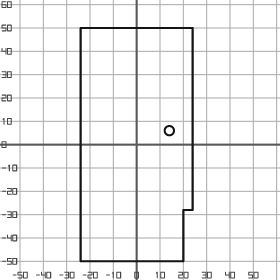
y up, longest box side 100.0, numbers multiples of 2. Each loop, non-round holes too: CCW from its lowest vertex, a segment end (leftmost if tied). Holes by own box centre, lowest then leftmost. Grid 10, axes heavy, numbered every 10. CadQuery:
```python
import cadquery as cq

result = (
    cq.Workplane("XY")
    .moveTo(-24.0, -50.0)
    .lineTo(20.0, -50.0)
    .lineTo(20.0, -28.0)
    .lineTo(24.0, -28.0)
    .lineTo(24.0, 50.0)
    .lineTo(-24.0, 50.0)
    .close()
    .moveTo(14.0, 6.0)
    .circle(2.0)
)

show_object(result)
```